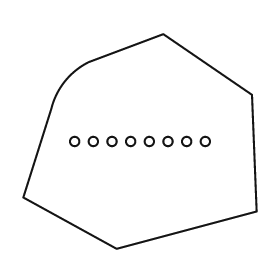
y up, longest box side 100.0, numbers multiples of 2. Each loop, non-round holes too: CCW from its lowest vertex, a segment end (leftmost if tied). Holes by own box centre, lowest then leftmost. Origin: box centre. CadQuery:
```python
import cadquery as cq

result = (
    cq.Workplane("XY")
    .moveTo(-10.0, -46.0)
    .lineTo(50.0, -30.0)
    .lineTo(48.0, 20.0)
    .lineTo(10.0, 46.0)
    .lineTo(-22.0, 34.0)
    .threePointArc((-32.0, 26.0), (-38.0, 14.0))
    .lineTo(-50.0, -24.0)
    .close()
    .moveTo(-28.0, 0.0)
    .circle(2.0)
    .moveTo(-20.0, 0.0)
    .circle(2.0)
    .moveTo(-12.0, 0.0)
    .circle(2.0)
    .moveTo(-4.0, 0.0)
    .circle(2.0)
    .moveTo(4.0, 0.0)
    .circle(2.0)
    .moveTo(12.0, 0.0)
    .circle(2.0)
    .moveTo(20.0, 0.0)
    .circle(2.0)
    .moveTo(28.0, 0.0)
    .circle(2.0)
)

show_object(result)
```